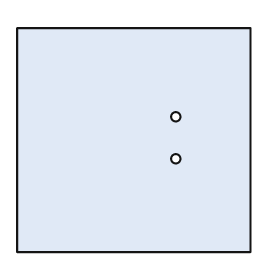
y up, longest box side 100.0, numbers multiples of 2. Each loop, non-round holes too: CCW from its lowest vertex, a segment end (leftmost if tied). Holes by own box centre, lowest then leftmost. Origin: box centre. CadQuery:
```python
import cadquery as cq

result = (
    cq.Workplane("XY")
    .moveTo(-50.0, -48.0)
    .lineTo(50.0, -48.0)
    .lineTo(50.0, 48.0)
    .lineTo(-50.0, 48.0)
    .close()
    .moveTo(18.0, -8.0)
    .circle(2.0)
    .moveTo(18.0, 10.0)
    .circle(2.0)
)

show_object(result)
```